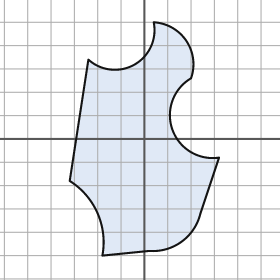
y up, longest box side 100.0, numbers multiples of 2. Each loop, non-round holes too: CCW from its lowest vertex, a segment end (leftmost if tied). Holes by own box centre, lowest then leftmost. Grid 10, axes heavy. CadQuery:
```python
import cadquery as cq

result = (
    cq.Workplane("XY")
    .moveTo(-18.0, -50.0)
    .lineTo(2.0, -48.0)
    .threePointArc((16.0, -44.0), (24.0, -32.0))
    .lineTo(32.0, -8.0)
    .threePointArc((12.0, 4.0), (20.0, 26.0))
    .threePointArc((18.0, 42.0), (4.0, 50.0))
    .threePointArc((-4.0, 32.0), (-24.0, 34.0))
    .lineTo(-32.0, -18.0)
    .threePointArc((-20.0, -32.0), (-18.0, -50.0))
    .close()
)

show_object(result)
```